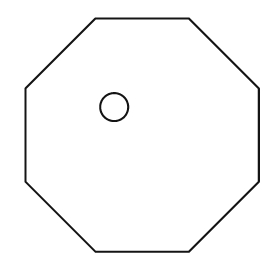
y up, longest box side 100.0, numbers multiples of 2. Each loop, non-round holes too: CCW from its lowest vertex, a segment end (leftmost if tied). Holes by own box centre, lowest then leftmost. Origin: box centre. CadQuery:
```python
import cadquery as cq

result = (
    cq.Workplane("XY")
    .moveTo(-20.0, -50.0)
    .lineTo(20.0, -50.0)
    .lineTo(50.0, -20.0)
    .lineTo(50.0, 20.0)
    .lineTo(20.0, 50.0)
    .lineTo(-20.0, 50.0)
    .lineTo(-50.0, 20.0)
    .lineTo(-50.0, -20.0)
    .close()
    .moveTo(-12.0, 12.0)
    .circle(6.0)
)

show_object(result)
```